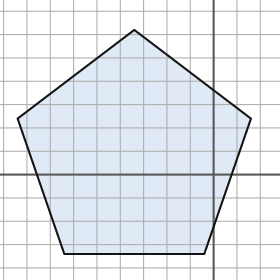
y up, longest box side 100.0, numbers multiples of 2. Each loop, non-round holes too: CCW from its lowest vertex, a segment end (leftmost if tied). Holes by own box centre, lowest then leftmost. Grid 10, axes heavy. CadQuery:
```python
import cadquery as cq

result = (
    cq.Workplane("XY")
    .moveTo(-64.0, -34.0)
    .lineTo(-4.0, -34.0)
    .lineTo(16.0, 24.0)
    .lineTo(-34.0, 62.0)
    .lineTo(-84.0, 24.0)
    .close()
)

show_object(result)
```